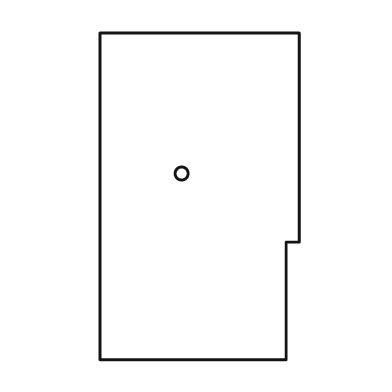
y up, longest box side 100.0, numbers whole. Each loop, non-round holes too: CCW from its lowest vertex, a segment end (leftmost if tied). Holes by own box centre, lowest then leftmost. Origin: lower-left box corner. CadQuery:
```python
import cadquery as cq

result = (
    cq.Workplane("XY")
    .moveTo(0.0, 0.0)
    .lineTo(57.0, 0.0)
    .lineTo(57.0, 36.0)
    .lineTo(61.0, 36.0)
    .lineTo(61.0, 100.0)
    .lineTo(0.0, 100.0)
    .close()
    .moveTo(25.0, 57.0)
    .circle(2.0)
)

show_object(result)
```